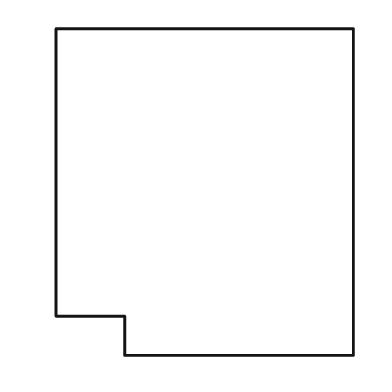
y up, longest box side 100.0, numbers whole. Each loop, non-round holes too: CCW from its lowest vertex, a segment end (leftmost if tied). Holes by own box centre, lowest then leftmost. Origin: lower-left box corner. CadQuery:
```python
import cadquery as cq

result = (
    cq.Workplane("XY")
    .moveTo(21.0, 0.0)
    .lineTo(91.0, 0.0)
    .lineTo(91.0, 100.0)
    .lineTo(0.0, 100.0)
    .lineTo(0.0, 12.0)
    .lineTo(21.0, 12.0)
    .close()
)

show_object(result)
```